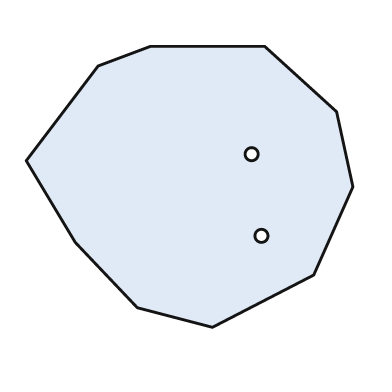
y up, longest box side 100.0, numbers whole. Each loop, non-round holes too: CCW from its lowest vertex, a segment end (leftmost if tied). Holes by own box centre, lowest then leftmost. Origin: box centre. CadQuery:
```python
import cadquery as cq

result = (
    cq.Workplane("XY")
    .moveTo(7.0, -43.0)
    .lineTo(38.0, -27.0)
    .lineTo(50.0, 0.0)
    .lineTo(45.0, 23.0)
    .lineTo(23.0, 43.0)
    .lineTo(-12.0, 43.0)
    .lineTo(-28.0, 37.0)
    .lineTo(-50.0, 8.0)
    .lineTo(-35.0, -17.0)
    .lineTo(-16.0, -37.0)
    .close()
    .moveTo(22.0, -15.0)
    .circle(2.0)
    .moveTo(19.0, 10.0)
    .circle(2.0)
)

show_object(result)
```